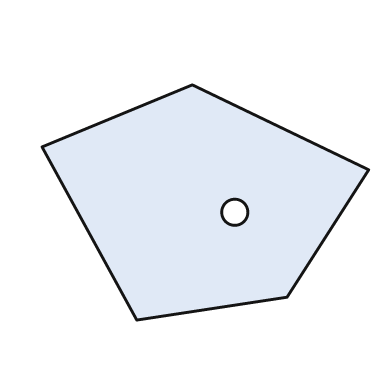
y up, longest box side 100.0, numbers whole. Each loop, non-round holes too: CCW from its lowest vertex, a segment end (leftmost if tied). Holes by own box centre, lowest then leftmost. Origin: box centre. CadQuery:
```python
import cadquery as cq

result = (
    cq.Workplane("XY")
    .moveTo(-21.0, -36.0)
    .lineTo(25.0, -29.0)
    .lineTo(50.0, 10.0)
    .lineTo(-4.0, 36.0)
    .lineTo(-50.0, 17.0)
    .close()
    .moveTo(9.0, -3.0)
    .circle(4.0)
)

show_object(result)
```